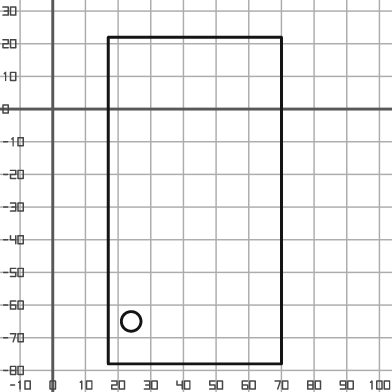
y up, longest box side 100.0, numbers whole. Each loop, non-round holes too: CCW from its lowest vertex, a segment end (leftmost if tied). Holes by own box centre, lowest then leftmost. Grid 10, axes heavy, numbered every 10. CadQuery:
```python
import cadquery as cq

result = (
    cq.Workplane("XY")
    .moveTo(17.0, -78.0)
    .lineTo(70.0, -78.0)
    .lineTo(70.0, 22.0)
    .lineTo(17.0, 22.0)
    .close()
    .moveTo(24.0, -65.0)
    .circle(3.0)
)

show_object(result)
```